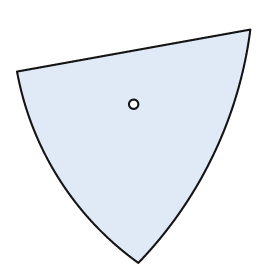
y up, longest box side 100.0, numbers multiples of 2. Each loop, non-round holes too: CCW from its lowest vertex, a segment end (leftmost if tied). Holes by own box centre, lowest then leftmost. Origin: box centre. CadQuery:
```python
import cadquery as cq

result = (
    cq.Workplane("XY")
    .moveTo(2.0, -50.0)
    .threePointArc((34.0, -4.0), (50.0, 50.0))
    .lineTo(-50.0, 32.0)
    .threePointArc((-32.0, -14.0), (2.0, -50.0))
    .close()
    .moveTo(0.0, 18.0)
    .circle(2.0)
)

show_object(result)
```